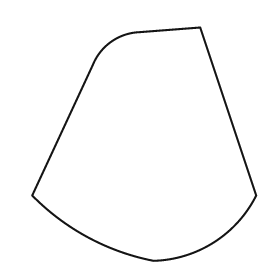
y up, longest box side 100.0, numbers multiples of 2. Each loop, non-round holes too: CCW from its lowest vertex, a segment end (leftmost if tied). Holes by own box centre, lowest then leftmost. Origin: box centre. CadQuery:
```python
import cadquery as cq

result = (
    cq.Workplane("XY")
    .moveTo(4.0, -50.0)
    .threePointArc((30.0, -42.0), (48.0, -22.0))
    .lineTo(24.0, 50.0)
    .lineTo(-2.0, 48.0)
    .threePointArc((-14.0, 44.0), (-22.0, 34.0))
    .lineTo(-48.0, -22.0)
    .threePointArc((-24.0, -40.0), (4.0, -50.0))
    .close()
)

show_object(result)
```